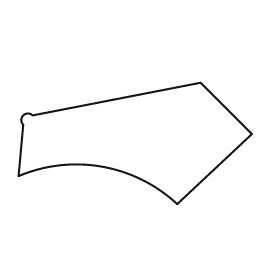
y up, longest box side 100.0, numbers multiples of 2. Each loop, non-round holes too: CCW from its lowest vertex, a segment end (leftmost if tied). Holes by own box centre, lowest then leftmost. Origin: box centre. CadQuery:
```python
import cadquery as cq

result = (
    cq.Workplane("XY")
    .moveTo(18.0, -26.0)
    .lineTo(50.0, 4.0)
    .lineTo(28.0, 26.0)
    .lineTo(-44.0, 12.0)
    .threePointArc((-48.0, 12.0), (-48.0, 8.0))
    .lineTo(-50.0, -14.0)
    .threePointArc((-14.0, -10.0), (18.0, -26.0))
    .close()
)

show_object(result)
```